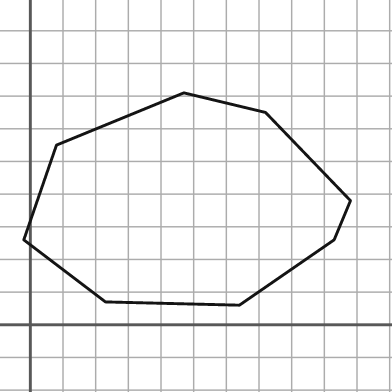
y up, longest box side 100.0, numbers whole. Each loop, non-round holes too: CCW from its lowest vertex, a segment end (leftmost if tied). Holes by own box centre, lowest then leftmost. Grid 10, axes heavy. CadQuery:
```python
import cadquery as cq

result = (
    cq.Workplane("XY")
    .moveTo(64.0, 6.0)
    .lineTo(93.0, 26.0)
    .lineTo(98.0, 38.0)
    .lineTo(72.0, 65.0)
    .lineTo(47.0, 71.0)
    .lineTo(8.0, 55.0)
    .lineTo(-2.0, 26.0)
    .lineTo(23.0, 7.0)
    .close()
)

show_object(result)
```